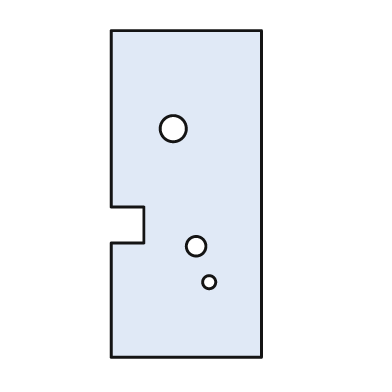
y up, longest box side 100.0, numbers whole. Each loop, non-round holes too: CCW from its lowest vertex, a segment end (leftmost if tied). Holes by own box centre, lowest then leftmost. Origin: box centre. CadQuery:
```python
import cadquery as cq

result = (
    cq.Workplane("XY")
    .moveTo(-23.0, -50.0)
    .lineTo(23.0, -50.0)
    .lineTo(23.0, 50.0)
    .lineTo(-23.0, 50.0)
    .lineTo(-23.0, -4.0)
    .lineTo(-13.0, -4.0)
    .lineTo(-13.0, -15.0)
    .lineTo(-23.0, -15.0)
    .close()
    .moveTo(7.0, -27.0)
    .circle(2.0)
    .moveTo(3.0, -16.0)
    .circle(3.0)
    .moveTo(-4.0, 20.0)
    .circle(4.0)
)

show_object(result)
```